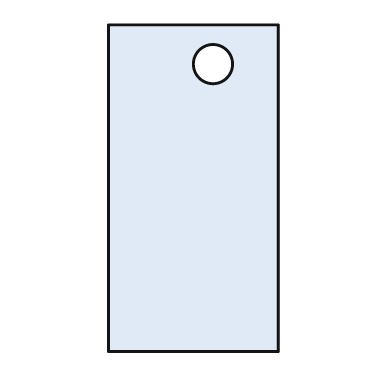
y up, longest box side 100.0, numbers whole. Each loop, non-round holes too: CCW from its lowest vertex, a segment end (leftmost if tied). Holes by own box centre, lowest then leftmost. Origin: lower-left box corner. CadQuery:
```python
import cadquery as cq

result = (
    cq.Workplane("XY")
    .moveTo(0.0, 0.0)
    .lineTo(52.0, 0.0)
    .lineTo(52.0, 100.0)
    .lineTo(0.0, 100.0)
    .close()
    .moveTo(32.0, 88.0)
    .circle(6.0)
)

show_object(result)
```